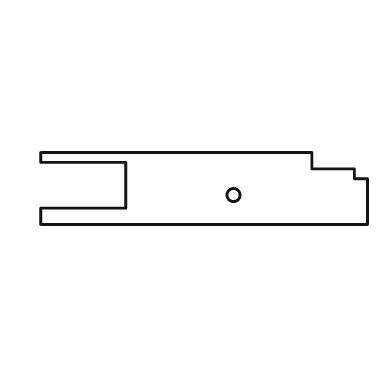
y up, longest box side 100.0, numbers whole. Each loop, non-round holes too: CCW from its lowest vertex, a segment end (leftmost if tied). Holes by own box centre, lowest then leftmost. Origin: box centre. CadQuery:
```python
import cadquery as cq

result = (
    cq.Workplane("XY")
    .moveTo(-50.0, -11.0)
    .lineTo(50.0, -11.0)
    .lineTo(50.0, 3.0)
    .lineTo(46.0, 3.0)
    .lineTo(46.0, 6.0)
    .lineTo(33.0, 6.0)
    .lineTo(33.0, 11.0)
    .lineTo(-50.0, 11.0)
    .lineTo(-50.0, 8.0)
    .lineTo(-24.0, 8.0)
    .lineTo(-24.0, -6.0)
    .lineTo(-50.0, -6.0)
    .close()
    .moveTo(9.0, -2.0)
    .circle(2.0)
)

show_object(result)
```